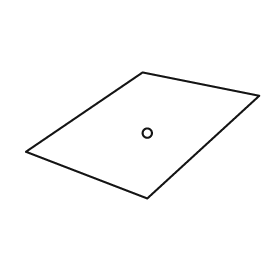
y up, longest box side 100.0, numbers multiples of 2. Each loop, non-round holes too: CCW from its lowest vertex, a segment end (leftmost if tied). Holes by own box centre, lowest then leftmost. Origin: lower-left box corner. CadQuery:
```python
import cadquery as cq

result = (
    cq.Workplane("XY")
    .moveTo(52.0, 0.0)
    .lineTo(100.0, 44.0)
    .lineTo(50.0, 54.0)
    .lineTo(0.0, 20.0)
    .close()
    .moveTo(52.0, 28.0)
    .circle(2.0)
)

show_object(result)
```